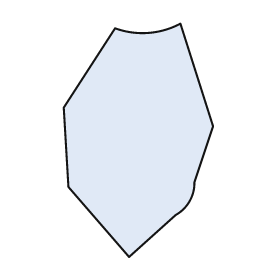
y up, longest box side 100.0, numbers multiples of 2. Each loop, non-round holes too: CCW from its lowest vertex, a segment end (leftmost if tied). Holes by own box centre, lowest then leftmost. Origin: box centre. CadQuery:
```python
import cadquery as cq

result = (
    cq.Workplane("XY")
    .moveTo(-4.0, -50.0)
    .lineTo(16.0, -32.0)
    .threePointArc((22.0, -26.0), (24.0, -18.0))
    .lineTo(32.0, 6.0)
    .lineTo(18.0, 50.0)
    .threePointArc((4.0, 46.0), (-10.0, 48.0))
    .lineTo(-32.0, 14.0)
    .lineTo(-30.0, -20.0)
    .close()
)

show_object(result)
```